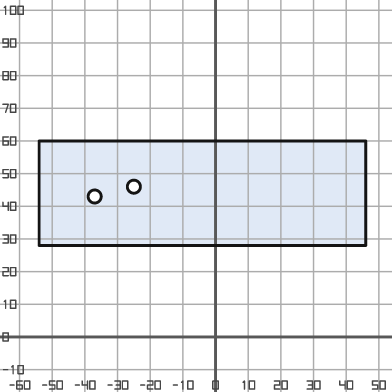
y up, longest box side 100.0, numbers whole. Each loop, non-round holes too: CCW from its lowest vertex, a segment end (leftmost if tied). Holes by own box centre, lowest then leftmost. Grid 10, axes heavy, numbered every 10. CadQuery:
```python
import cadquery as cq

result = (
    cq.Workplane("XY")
    .moveTo(-54.0, 28.0)
    .lineTo(46.0, 28.0)
    .lineTo(46.0, 60.0)
    .lineTo(-54.0, 60.0)
    .close()
    .moveTo(-37.0, 43.0)
    .circle(2.0)
    .moveTo(-25.0, 46.0)
    .circle(2.0)
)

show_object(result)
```